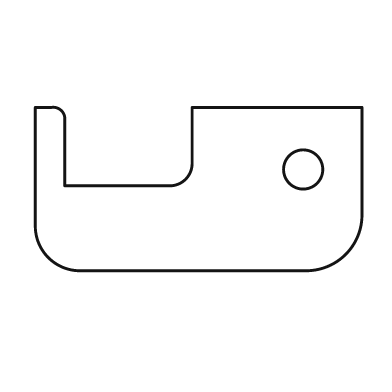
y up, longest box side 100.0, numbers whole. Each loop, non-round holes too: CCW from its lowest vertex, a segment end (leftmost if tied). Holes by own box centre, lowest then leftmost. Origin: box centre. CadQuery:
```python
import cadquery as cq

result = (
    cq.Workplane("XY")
    .moveTo(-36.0, -25.0)
    .lineTo(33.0, -25.0)
    .threePointArc((45.0, -20.0), (50.0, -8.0))
    .lineTo(50.0, 25.0)
    .lineTo(-2.0, 25.0)
    .lineTo(-2.0, 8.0)
    .threePointArc((-4.0, 3.0), (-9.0, 1.0))
    .lineTo(-41.0, 1.0)
    .lineTo(-41.0, 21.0)
    .threePointArc((-42.0, 24.0), (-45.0, 25.0))
    .lineTo(-50.0, 25.0)
    .lineTo(-50.0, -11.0)
    .threePointArc((-46.0, -21.0), (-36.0, -25.0))
    .close()
    .moveTo(32.0, 6.0)
    .circle(6.0)
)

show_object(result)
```